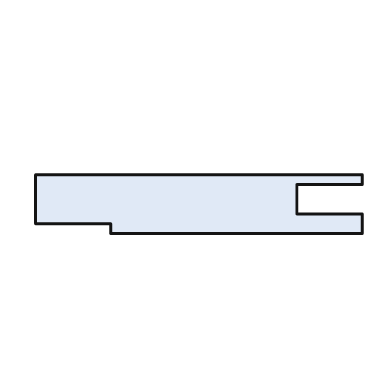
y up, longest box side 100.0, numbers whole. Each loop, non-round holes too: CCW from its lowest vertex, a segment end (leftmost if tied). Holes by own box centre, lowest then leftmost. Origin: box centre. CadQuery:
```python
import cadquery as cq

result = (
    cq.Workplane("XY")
    .moveTo(-27.0, -9.0)
    .lineTo(50.0, -9.0)
    .lineTo(50.0, -3.0)
    .lineTo(30.0, -3.0)
    .lineTo(30.0, 6.0)
    .lineTo(50.0, 6.0)
    .lineTo(50.0, 9.0)
    .lineTo(-50.0, 9.0)
    .lineTo(-50.0, -6.0)
    .lineTo(-27.0, -6.0)
    .close()
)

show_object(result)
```